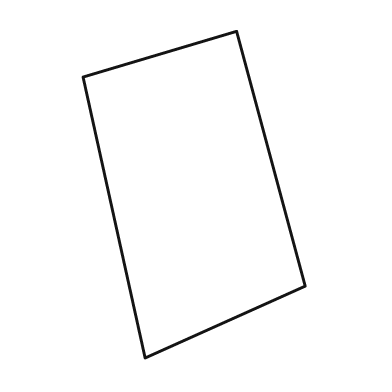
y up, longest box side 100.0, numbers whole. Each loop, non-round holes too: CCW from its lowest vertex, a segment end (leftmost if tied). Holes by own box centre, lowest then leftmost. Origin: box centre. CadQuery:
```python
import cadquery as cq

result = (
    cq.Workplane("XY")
    .moveTo(-15.0, -50.0)
    .lineTo(34.0, -28.0)
    .lineTo(13.0, 50.0)
    .lineTo(-34.0, 36.0)
    .close()
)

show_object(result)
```